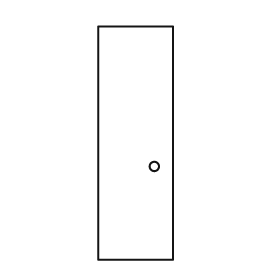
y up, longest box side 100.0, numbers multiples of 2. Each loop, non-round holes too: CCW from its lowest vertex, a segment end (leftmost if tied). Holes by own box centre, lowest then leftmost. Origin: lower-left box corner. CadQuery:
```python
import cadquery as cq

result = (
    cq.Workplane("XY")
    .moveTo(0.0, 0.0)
    .lineTo(32.0, 0.0)
    .lineTo(32.0, 100.0)
    .lineTo(0.0, 100.0)
    .close()
    .moveTo(24.0, 40.0)
    .circle(2.0)
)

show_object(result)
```